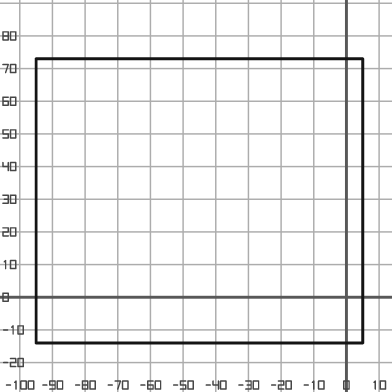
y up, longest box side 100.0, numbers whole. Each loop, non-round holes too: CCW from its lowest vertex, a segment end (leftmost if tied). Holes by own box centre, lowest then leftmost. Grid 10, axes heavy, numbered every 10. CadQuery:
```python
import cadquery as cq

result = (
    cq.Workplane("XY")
    .moveTo(-95.0, -14.0)
    .lineTo(5.0, -14.0)
    .lineTo(5.0, 73.0)
    .lineTo(-95.0, 73.0)
    .close()
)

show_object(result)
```